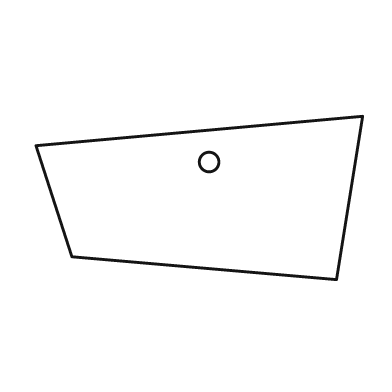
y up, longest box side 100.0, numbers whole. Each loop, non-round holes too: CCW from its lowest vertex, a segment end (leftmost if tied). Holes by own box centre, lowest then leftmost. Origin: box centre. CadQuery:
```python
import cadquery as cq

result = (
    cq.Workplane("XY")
    .moveTo(42.0, -25.0)
    .lineTo(50.0, 25.0)
    .lineTo(-50.0, 16.0)
    .lineTo(-39.0, -18.0)
    .close()
    .moveTo(3.0, 11.0)
    .circle(3.0)
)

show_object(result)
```